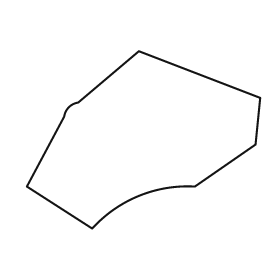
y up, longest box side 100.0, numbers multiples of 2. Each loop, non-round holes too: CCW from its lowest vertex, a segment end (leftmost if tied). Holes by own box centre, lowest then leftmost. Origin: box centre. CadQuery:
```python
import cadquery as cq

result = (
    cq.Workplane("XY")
    .moveTo(-22.0, -38.0)
    .threePointArc((-2.0, -24.0), (22.0, -20.0))
    .lineTo(48.0, -2.0)
    .lineTo(50.0, 18.0)
    .lineTo(-2.0, 38.0)
    .lineTo(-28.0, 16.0)
    .threePointArc((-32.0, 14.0), (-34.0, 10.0))
    .lineTo(-50.0, -20.0)
    .close()
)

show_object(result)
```